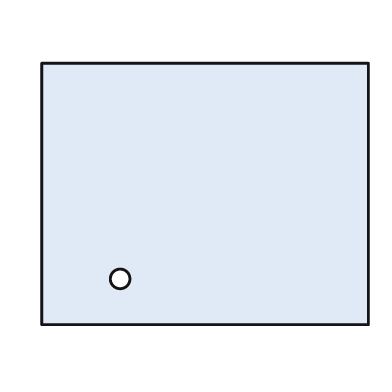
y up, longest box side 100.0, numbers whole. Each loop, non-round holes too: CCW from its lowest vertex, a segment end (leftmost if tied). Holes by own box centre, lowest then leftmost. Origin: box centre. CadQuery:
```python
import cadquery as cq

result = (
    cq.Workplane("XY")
    .moveTo(-50.0, -40.0)
    .lineTo(50.0, -40.0)
    .lineTo(50.0, 40.0)
    .lineTo(-50.0, 40.0)
    .close()
    .moveTo(-26.0, -26.0)
    .circle(3.0)
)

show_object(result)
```